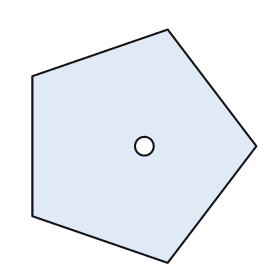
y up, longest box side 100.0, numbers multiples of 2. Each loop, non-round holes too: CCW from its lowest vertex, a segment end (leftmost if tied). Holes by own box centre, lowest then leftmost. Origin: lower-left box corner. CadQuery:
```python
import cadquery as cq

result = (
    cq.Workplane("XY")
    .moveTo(58.0, 0.0)
    .lineTo(96.0, 50.0)
    .lineTo(58.0, 100.0)
    .lineTo(0.0, 80.0)
    .lineTo(0.0, 20.0)
    .close()
    .moveTo(48.0, 50.0)
    .circle(4.0)
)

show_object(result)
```